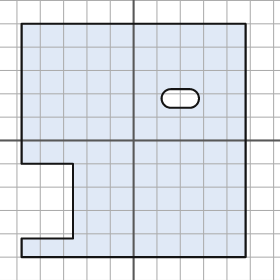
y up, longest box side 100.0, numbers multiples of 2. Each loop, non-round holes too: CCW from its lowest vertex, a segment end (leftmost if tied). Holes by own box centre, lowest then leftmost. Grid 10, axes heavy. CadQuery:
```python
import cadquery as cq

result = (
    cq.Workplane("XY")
    .moveTo(-48.0, -50.0)
    .lineTo(48.0, -50.0)
    .lineTo(48.0, 50.0)
    .lineTo(-48.0, 50.0)
    .lineTo(-48.0, -10.0)
    .lineTo(-26.0, -10.0)
    .lineTo(-26.0, -42.0)
    .lineTo(-48.0, -42.0)
    .close()
    .moveTo(16.0, 14.0)
    .lineTo(24.0, 14.0)
    .threePointArc((28.0, 18.0), (24.0, 22.0))
    .lineTo(16.0, 22.0)
    .threePointArc((12.0, 18.0), (16.0, 14.0))
    .close()
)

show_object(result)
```